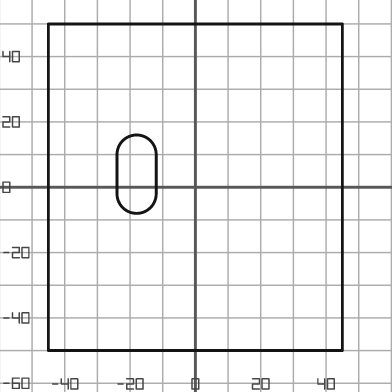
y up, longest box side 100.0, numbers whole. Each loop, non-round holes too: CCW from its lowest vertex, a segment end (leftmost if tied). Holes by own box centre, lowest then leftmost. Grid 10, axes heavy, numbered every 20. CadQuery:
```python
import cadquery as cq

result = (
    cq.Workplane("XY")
    .moveTo(-45.0, -50.0)
    .lineTo(45.0, -50.0)
    .lineTo(45.0, 50.0)
    .lineTo(-45.0, 50.0)
    .close()
    .moveTo(-24.0, -2.0)
    .threePointArc((-18.0, -8.0), (-12.0, -2.0))
    .lineTo(-12.0, 10.0)
    .threePointArc((-18.0, 16.0), (-24.0, 10.0))
    .close()
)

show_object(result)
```